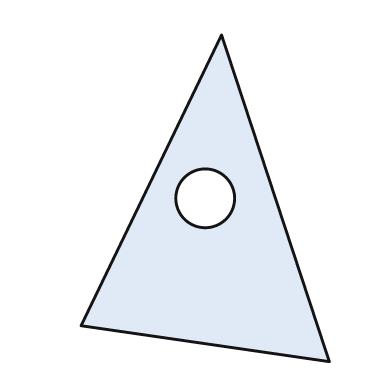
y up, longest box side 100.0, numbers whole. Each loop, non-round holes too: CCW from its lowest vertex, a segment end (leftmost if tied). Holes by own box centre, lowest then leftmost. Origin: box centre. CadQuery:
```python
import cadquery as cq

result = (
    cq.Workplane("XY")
    .moveTo(38.0, -50.0)
    .lineTo(5.0, 50.0)
    .lineTo(-38.0, -39.0)
    .close()
    .moveTo(0.0, 0.0)
    .circle(9.0)
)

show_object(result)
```